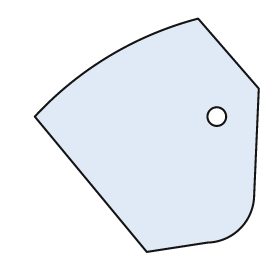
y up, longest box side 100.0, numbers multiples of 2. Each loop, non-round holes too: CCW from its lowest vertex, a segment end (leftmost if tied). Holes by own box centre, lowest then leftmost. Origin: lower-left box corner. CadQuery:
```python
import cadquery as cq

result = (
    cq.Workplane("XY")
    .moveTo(48.0, 0.0)
    .lineTo(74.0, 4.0)
    .threePointArc((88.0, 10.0), (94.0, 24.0))
    .lineTo(96.0, 70.0)
    .lineTo(70.0, 100.0)
    .threePointArc((32.0, 84.0), (0.0, 58.0))
    .close()
    .moveTo(78.0, 58.0)
    .circle(4.0)
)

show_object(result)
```